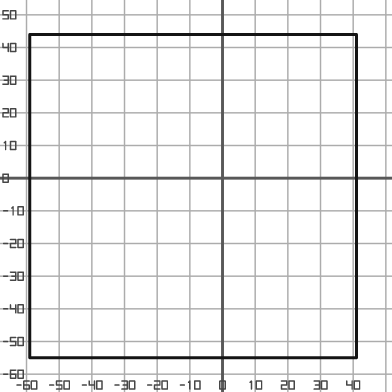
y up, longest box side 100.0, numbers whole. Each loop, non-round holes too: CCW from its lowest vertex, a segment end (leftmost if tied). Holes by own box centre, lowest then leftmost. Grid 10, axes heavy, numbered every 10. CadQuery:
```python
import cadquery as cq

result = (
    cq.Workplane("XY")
    .moveTo(-59.0, -55.0)
    .lineTo(41.0, -55.0)
    .lineTo(41.0, 44.0)
    .lineTo(-59.0, 44.0)
    .close()
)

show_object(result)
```